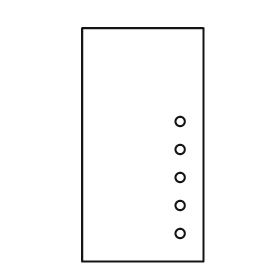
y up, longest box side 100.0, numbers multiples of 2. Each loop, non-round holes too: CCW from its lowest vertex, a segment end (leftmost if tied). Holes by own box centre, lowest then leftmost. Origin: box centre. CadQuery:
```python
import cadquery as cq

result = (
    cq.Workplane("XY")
    .moveTo(-26.0, -50.0)
    .lineTo(26.0, -50.0)
    .lineTo(26.0, 50.0)
    .lineTo(-26.0, 50.0)
    .close()
    .moveTo(16.0, -38.0)
    .circle(2.0)
    .moveTo(16.0, -26.0)
    .circle(2.0)
    .moveTo(16.0, -14.0)
    .circle(2.0)
    .moveTo(16.0, -2.0)
    .circle(2.0)
    .moveTo(16.0, 10.0)
    .circle(2.0)
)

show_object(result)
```